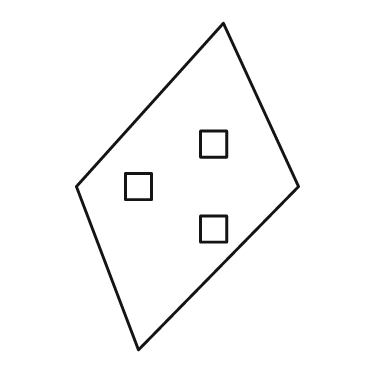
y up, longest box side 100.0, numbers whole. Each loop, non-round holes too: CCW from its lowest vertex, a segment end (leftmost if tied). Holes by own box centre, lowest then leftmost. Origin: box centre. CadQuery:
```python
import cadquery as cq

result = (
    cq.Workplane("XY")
    .moveTo(-15.0, -50.0)
    .lineTo(34.0, 0.0)
    .lineTo(11.0, 50.0)
    .lineTo(-34.0, 0.0)
    .close()
    .moveTo(4.0, -17.0)
    .lineTo(12.0, -17.0)
    .lineTo(12.0, -9.0)
    .lineTo(4.0, -9.0)
    .close()
    .moveTo(-19.0, -4.0)
    .lineTo(-11.0, -4.0)
    .lineTo(-11.0, 4.0)
    .lineTo(-19.0, 4.0)
    .close()
    .moveTo(4.0, 9.0)
    .lineTo(12.0, 9.0)
    .lineTo(12.0, 17.0)
    .lineTo(4.0, 17.0)
    .close()
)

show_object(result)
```